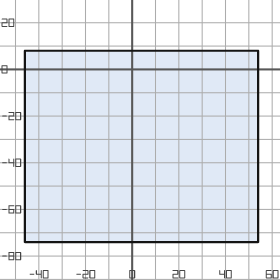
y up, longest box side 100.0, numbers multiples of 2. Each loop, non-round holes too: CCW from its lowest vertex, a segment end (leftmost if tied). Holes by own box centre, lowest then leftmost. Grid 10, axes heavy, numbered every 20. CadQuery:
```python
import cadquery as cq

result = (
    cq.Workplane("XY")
    .moveTo(-46.0, -74.0)
    .lineTo(54.0, -74.0)
    .lineTo(54.0, 8.0)
    .lineTo(-46.0, 8.0)
    .close()
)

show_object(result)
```